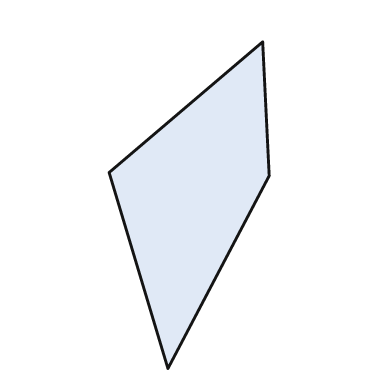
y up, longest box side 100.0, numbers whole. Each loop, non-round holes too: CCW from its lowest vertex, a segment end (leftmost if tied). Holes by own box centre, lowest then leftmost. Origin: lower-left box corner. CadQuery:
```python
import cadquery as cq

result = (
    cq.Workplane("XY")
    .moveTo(18.0, 0.0)
    .lineTo(49.0, 59.0)
    .lineTo(47.0, 100.0)
    .lineTo(0.0, 60.0)
    .close()
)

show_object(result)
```